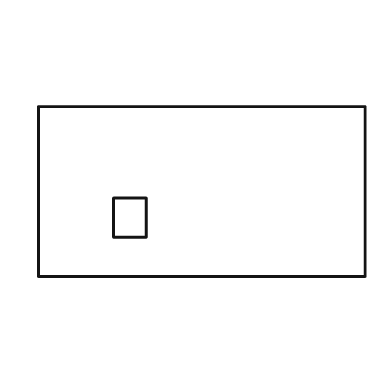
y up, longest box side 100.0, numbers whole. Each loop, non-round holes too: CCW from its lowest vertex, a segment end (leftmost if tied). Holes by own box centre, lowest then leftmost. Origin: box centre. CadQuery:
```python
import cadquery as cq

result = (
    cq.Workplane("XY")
    .moveTo(-50.0, -26.0)
    .lineTo(50.0, -26.0)
    .lineTo(50.0, 26.0)
    .lineTo(-50.0, 26.0)
    .close()
    .moveTo(-27.0, -14.0)
    .lineTo(-17.0, -14.0)
    .lineTo(-17.0, -2.0)
    .lineTo(-27.0, -2.0)
    .close()
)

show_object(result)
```